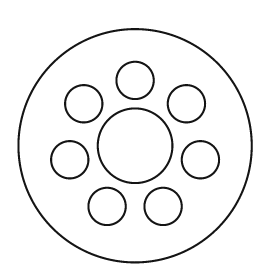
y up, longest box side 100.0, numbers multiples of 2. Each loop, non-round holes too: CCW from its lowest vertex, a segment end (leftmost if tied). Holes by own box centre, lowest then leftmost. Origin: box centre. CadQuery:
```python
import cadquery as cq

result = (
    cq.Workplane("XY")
    .moveTo(0.0, 0.0)
    .circle(50.0)
    .moveTo(-12.0, -26.0)
    .circle(8.0)
    .moveTo(12.0, -26.0)
    .circle(8.0)
    .moveTo(-28.0, -6.0)
    .circle(8.0)
    .moveTo(28.0, -6.0)
    .circle(8.0)
    .moveTo(0.0, 0.0)
    .circle(16.0)
    .moveTo(-22.0, 18.0)
    .circle(8.0)
    .moveTo(22.0, 18.0)
    .circle(8.0)
    .moveTo(0.0, 28.0)
    .circle(8.0)
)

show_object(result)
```